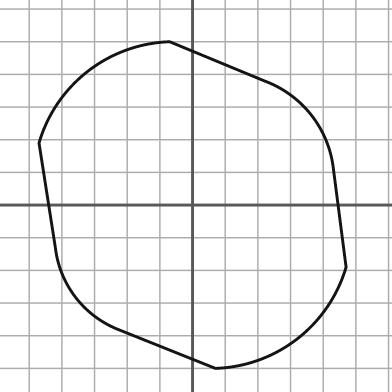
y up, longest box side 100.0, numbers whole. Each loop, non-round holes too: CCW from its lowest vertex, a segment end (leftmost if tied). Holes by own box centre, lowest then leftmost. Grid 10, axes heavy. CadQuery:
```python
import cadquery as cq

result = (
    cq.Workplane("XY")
    .moveTo(7.0, -50.0)
    .threePointArc((32.0, -41.0), (47.0, -19.0))
    .lineTo(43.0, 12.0)
    .threePointArc((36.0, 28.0), (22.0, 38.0))
    .lineTo(-7.0, 50.0)
    .threePointArc((-32.0, 41.0), (-47.0, 19.0))
    .lineTo(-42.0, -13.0)
    .threePointArc((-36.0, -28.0), (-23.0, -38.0))
    .close()
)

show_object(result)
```